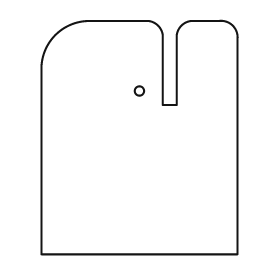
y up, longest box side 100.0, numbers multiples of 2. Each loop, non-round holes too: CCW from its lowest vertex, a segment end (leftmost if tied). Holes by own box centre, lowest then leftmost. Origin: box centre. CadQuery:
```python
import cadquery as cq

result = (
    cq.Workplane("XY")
    .moveTo(-42.0, -50.0)
    .lineTo(42.0, -50.0)
    .lineTo(42.0, 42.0)
    .threePointArc((40.0, 48.0), (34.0, 50.0))
    .lineTo(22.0, 50.0)
    .threePointArc((18.0, 48.0), (16.0, 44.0))
    .lineTo(16.0, 14.0)
    .lineTo(10.0, 14.0)
    .lineTo(10.0, 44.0)
    .threePointArc((8.0, 48.0), (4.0, 50.0))
    .lineTo(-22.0, 50.0)
    .threePointArc((-36.0, 44.0), (-42.0, 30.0))
    .close()
    .moveTo(0.0, 20.0)
    .circle(2.0)
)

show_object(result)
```